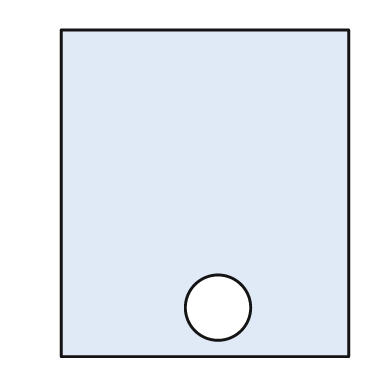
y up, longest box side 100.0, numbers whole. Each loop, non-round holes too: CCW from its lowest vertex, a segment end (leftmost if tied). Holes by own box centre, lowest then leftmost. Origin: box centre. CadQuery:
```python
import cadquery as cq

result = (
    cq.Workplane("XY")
    .moveTo(-44.0, -50.0)
    .lineTo(44.0, -50.0)
    .lineTo(44.0, 50.0)
    .lineTo(-44.0, 50.0)
    .close()
    .moveTo(4.0, -35.0)
    .circle(10.0)
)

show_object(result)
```